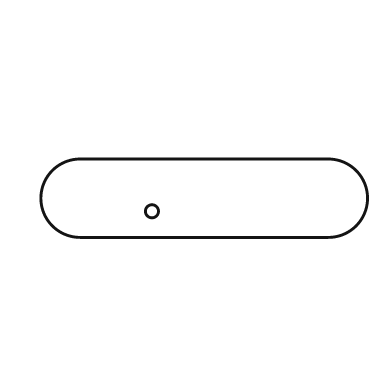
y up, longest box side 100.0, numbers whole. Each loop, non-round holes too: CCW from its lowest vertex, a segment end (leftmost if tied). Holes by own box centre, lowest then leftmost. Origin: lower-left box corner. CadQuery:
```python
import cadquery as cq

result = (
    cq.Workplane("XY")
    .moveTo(12.0, 0.0)
    .lineTo(88.0, 0.0)
    .threePointArc((100.0, 12.0), (88.0, 24.0))
    .lineTo(12.0, 24.0)
    .threePointArc((0.0, 12.0), (12.0, 0.0))
    .close()
    .moveTo(34.0, 8.0)
    .circle(2.0)
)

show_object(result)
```